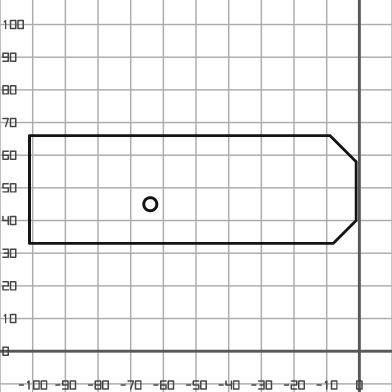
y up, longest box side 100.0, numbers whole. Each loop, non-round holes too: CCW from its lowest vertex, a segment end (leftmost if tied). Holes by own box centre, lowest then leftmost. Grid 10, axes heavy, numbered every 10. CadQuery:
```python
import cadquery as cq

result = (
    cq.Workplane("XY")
    .moveTo(-101.0, 33.0)
    .lineTo(-8.0, 33.0)
    .lineTo(-1.0, 40.0)
    .lineTo(-1.0, 58.0)
    .lineTo(-9.0, 66.0)
    .lineTo(-101.0, 66.0)
    .close()
    .moveTo(-64.0, 45.0)
    .circle(2.0)
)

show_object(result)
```